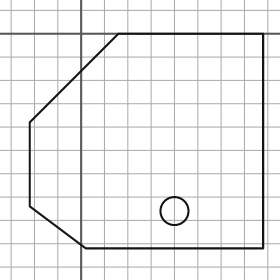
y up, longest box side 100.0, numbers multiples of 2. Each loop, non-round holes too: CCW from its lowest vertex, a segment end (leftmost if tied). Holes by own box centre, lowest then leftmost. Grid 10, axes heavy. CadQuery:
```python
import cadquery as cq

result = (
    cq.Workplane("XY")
    .moveTo(2.0, -92.0)
    .lineTo(78.0, -92.0)
    .lineTo(78.0, 0.0)
    .lineTo(16.0, 0.0)
    .lineTo(-22.0, -38.0)
    .lineTo(-22.0, -74.0)
    .close()
    .moveTo(40.0, -76.0)
    .circle(6.0)
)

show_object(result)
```